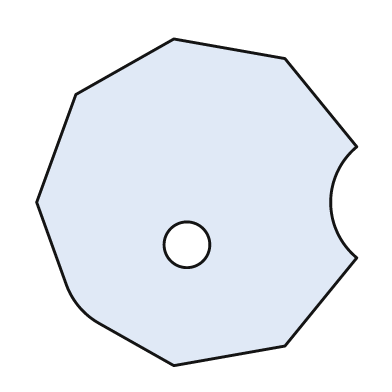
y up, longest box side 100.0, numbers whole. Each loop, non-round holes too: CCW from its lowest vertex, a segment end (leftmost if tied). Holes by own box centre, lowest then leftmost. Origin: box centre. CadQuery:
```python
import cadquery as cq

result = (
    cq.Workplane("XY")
    .moveTo(-7.0, -50.0)
    .lineTo(27.0, -44.0)
    .lineTo(49.0, -17.0)
    .threePointArc((41.0, 0.0), (49.0, 17.0))
    .lineTo(27.0, 44.0)
    .lineTo(-7.0, 50.0)
    .lineTo(-37.0, 33.0)
    .lineTo(-49.0, 0.0)
    .lineTo(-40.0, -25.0)
    .threePointArc((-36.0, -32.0), (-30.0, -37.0))
    .close()
    .moveTo(-3.0, -13.0)
    .circle(7.0)
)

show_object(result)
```